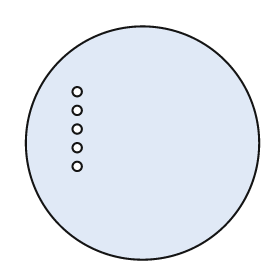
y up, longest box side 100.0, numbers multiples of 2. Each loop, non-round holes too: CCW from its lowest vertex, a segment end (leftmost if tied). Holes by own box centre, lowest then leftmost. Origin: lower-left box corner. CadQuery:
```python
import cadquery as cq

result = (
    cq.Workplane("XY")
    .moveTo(50.0, 50.0)
    .circle(50.0)
    .moveTo(22.0, 40.0)
    .circle(2.0)
    .moveTo(22.0, 48.0)
    .circle(2.0)
    .moveTo(22.0, 56.0)
    .circle(2.0)
    .moveTo(22.0, 64.0)
    .circle(2.0)
    .moveTo(22.0, 72.0)
    .circle(2.0)
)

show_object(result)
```